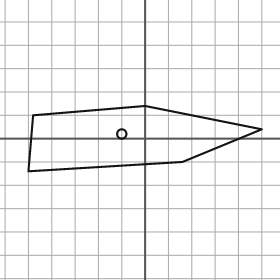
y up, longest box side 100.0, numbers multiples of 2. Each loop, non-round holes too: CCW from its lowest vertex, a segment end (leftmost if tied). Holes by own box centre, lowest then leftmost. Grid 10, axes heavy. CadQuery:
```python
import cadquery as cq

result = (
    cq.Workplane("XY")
    .moveTo(-50.0, -14.0)
    .lineTo(16.0, -10.0)
    .lineTo(50.0, 4.0)
    .lineTo(0.0, 14.0)
    .lineTo(-48.0, 10.0)
    .close()
    .moveTo(-10.0, 2.0)
    .circle(2.0)
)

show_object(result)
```